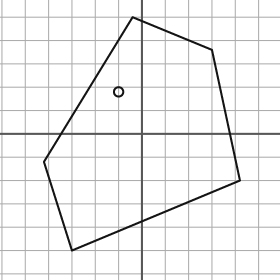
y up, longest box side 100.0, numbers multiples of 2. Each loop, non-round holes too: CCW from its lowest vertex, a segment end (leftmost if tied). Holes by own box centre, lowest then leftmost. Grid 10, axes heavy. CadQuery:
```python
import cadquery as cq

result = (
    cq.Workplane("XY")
    .moveTo(-30.0, -50.0)
    .lineTo(42.0, -20.0)
    .lineTo(30.0, 36.0)
    .lineTo(-4.0, 50.0)
    .lineTo(-42.0, -12.0)
    .close()
    .moveTo(-10.0, 18.0)
    .circle(2.0)
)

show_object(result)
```